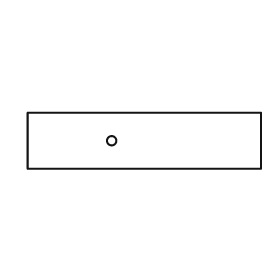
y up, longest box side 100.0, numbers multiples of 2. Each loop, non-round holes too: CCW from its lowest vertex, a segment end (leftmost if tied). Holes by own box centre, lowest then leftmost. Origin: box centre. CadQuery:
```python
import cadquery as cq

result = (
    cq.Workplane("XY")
    .moveTo(-50.0, -12.0)
    .lineTo(50.0, -12.0)
    .lineTo(50.0, 12.0)
    .lineTo(-50.0, 12.0)
    .close()
    .moveTo(-14.0, 0.0)
    .circle(2.0)
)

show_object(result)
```